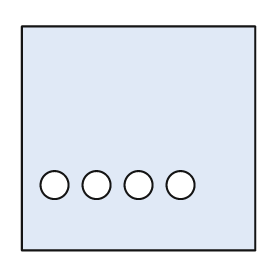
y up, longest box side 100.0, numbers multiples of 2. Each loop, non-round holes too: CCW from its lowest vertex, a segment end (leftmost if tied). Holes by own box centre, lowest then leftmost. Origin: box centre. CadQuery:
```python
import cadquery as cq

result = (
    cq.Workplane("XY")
    .moveTo(-50.0, -48.0)
    .lineTo(50.0, -48.0)
    .lineTo(50.0, 48.0)
    .lineTo(-50.0, 48.0)
    .close()
    .moveTo(-36.0, -20.0)
    .circle(6.0)
    .moveTo(-18.0, -20.0)
    .circle(6.0)
    .moveTo(0.0, -20.0)
    .circle(6.0)
    .moveTo(18.0, -20.0)
    .circle(6.0)
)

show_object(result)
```